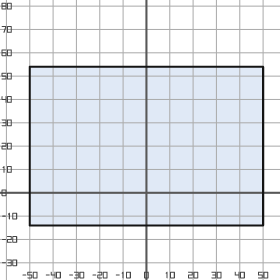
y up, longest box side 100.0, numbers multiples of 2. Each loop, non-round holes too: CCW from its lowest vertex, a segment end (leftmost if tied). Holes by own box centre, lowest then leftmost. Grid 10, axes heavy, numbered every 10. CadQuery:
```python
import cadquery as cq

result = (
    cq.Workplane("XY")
    .moveTo(-50.0, -14.0)
    .lineTo(50.0, -14.0)
    .lineTo(50.0, 54.0)
    .lineTo(-50.0, 54.0)
    .close()
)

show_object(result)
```